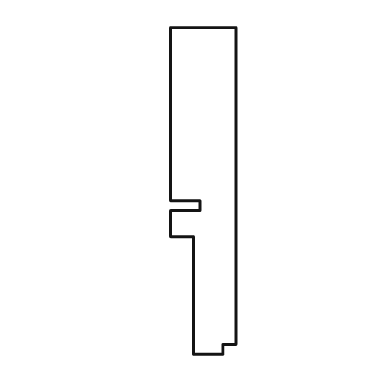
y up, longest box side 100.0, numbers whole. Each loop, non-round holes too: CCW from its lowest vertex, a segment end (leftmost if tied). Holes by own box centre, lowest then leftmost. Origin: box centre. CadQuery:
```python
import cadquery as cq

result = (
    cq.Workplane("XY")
    .moveTo(-3.0, -50.0)
    .lineTo(6.0, -50.0)
    .lineTo(6.0, -47.0)
    .lineTo(10.0, -47.0)
    .lineTo(10.0, 50.0)
    .lineTo(-10.0, 50.0)
    .lineTo(-10.0, -3.0)
    .lineTo(-1.0, -3.0)
    .lineTo(-1.0, -6.0)
    .lineTo(-10.0, -6.0)
    .lineTo(-10.0, -14.0)
    .lineTo(-3.0, -14.0)
    .close()
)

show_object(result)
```